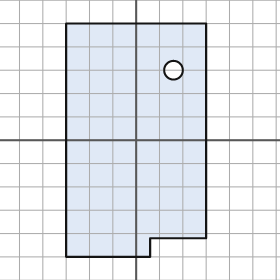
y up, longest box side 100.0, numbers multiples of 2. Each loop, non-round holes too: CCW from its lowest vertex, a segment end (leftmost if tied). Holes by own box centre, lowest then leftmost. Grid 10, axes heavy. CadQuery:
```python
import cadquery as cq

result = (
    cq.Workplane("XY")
    .moveTo(-30.0, -50.0)
    .lineTo(6.0, -50.0)
    .lineTo(6.0, -42.0)
    .lineTo(30.0, -42.0)
    .lineTo(30.0, 50.0)
    .lineTo(-30.0, 50.0)
    .close()
    .moveTo(16.0, 30.0)
    .circle(4.0)
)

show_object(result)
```